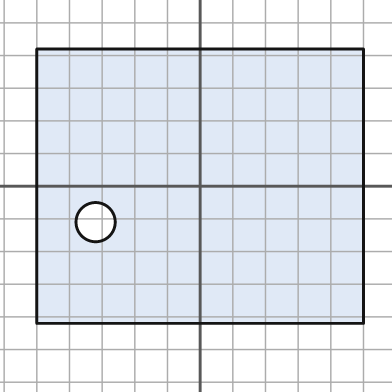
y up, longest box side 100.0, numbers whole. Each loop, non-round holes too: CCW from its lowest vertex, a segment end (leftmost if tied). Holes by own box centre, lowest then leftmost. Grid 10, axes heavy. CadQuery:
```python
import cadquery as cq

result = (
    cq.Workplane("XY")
    .moveTo(-50.0, -42.0)
    .lineTo(50.0, -42.0)
    .lineTo(50.0, 42.0)
    .lineTo(-50.0, 42.0)
    .close()
    .moveTo(-32.0, -11.0)
    .circle(6.0)
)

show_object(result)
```